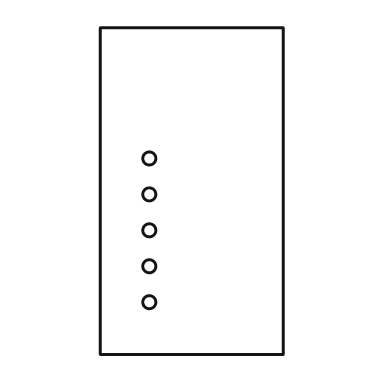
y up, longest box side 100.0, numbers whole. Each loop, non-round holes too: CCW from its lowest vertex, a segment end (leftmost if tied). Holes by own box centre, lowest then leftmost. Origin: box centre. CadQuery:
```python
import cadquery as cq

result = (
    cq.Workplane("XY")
    .moveTo(-28.0, -50.0)
    .lineTo(28.0, -50.0)
    .lineTo(28.0, 50.0)
    .lineTo(-28.0, 50.0)
    .close()
    .moveTo(-13.0, -34.0)
    .circle(2.0)
    .moveTo(-13.0, -23.0)
    .circle(2.0)
    .moveTo(-13.0, -12.0)
    .circle(2.0)
    .moveTo(-13.0, -1.0)
    .circle(2.0)
    .moveTo(-13.0, 10.0)
    .circle(2.0)
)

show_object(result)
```